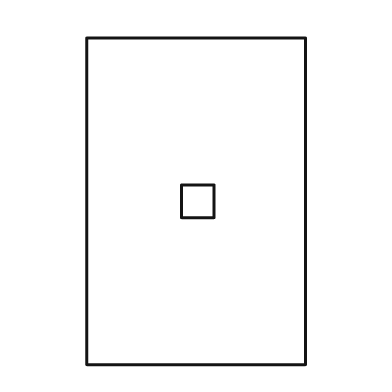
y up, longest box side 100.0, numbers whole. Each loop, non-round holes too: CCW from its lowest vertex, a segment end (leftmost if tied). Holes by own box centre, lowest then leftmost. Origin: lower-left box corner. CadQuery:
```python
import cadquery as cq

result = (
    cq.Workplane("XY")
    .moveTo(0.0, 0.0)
    .lineTo(67.0, 0.0)
    .lineTo(67.0, 100.0)
    .lineTo(0.0, 100.0)
    .close()
    .moveTo(29.0, 45.0)
    .lineTo(39.0, 45.0)
    .lineTo(39.0, 55.0)
    .lineTo(29.0, 55.0)
    .close()
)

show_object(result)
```